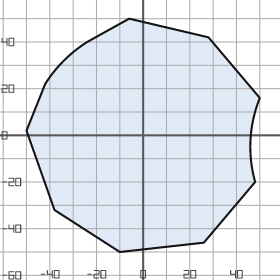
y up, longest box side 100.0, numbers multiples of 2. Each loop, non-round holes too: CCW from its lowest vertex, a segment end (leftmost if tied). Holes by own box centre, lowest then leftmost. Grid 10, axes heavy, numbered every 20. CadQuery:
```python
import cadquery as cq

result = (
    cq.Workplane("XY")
    .moveTo(-10.0, -50.0)
    .lineTo(26.0, -46.0)
    .lineTo(48.0, -20.0)
    .threePointArc((46.0, -2.0), (50.0, 16.0))
    .lineTo(28.0, 42.0)
    .lineTo(-6.0, 50.0)
    .lineTo(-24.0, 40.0)
    .threePointArc((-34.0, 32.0), (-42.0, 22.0))
    .lineTo(-50.0, 2.0)
    .lineTo(-38.0, -32.0)
    .close()
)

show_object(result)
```